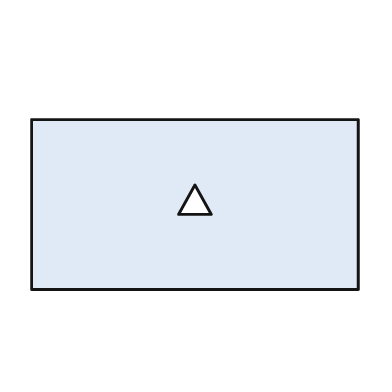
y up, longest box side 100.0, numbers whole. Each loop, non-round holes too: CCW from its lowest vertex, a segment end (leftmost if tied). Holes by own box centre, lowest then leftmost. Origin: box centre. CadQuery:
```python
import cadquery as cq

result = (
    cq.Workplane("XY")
    .moveTo(-50.0, -26.0)
    .lineTo(50.0, -26.0)
    .lineTo(50.0, 26.0)
    .lineTo(-50.0, 26.0)
    .close()
    .moveTo(-5.0, -3.0)
    .lineTo(5.0, -3.0)
    .lineTo(0.0, 6.0)
    .close()
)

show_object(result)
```